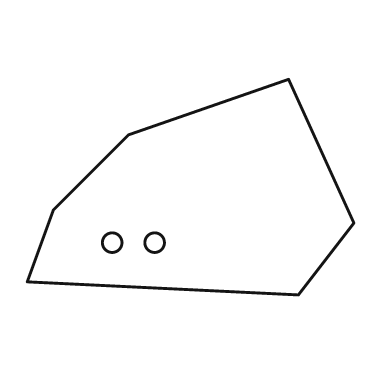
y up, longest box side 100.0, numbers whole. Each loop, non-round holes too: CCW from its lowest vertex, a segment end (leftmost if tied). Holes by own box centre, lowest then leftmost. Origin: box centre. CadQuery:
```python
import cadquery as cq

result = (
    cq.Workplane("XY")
    .moveTo(33.0, -33.0)
    .lineTo(50.0, -11.0)
    .lineTo(30.0, 33.0)
    .lineTo(-19.0, 16.0)
    .lineTo(-42.0, -7.0)
    .lineTo(-50.0, -29.0)
    .close()
    .moveTo(-24.0, -17.0)
    .circle(3.0)
    .moveTo(-11.0, -17.0)
    .circle(3.0)
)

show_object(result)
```